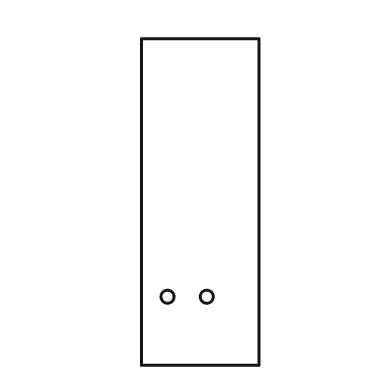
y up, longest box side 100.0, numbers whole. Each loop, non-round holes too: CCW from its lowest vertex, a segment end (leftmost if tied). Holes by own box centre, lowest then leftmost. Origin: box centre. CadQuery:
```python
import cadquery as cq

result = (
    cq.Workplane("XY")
    .moveTo(-18.0, -50.0)
    .lineTo(18.0, -50.0)
    .lineTo(18.0, 50.0)
    .lineTo(-18.0, 50.0)
    .close()
    .moveTo(-10.0, -29.0)
    .circle(2.0)
    .moveTo(2.0, -29.0)
    .circle(2.0)
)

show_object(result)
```